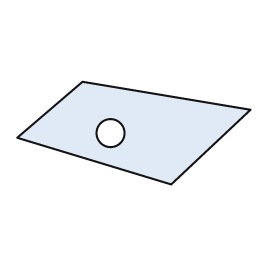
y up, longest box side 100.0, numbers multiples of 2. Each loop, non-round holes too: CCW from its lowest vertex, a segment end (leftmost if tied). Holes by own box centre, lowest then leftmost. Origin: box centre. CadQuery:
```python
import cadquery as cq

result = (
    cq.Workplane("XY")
    .moveTo(16.0, -22.0)
    .lineTo(50.0, 10.0)
    .lineTo(-22.0, 22.0)
    .lineTo(-50.0, -2.0)
    .close()
    .moveTo(-10.0, 0.0)
    .circle(6.0)
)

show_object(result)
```